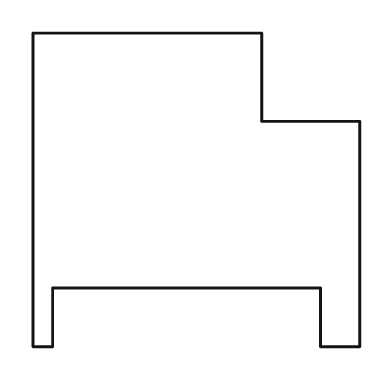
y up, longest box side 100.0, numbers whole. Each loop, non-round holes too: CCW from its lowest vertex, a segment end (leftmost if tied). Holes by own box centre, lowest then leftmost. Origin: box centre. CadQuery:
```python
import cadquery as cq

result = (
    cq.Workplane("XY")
    .moveTo(-50.0, -48.0)
    .lineTo(-44.0, -48.0)
    .lineTo(-44.0, -30.0)
    .lineTo(38.0, -30.0)
    .lineTo(38.0, -48.0)
    .lineTo(50.0, -48.0)
    .lineTo(50.0, 21.0)
    .lineTo(20.0, 21.0)
    .lineTo(20.0, 48.0)
    .lineTo(-50.0, 48.0)
    .close()
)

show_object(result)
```